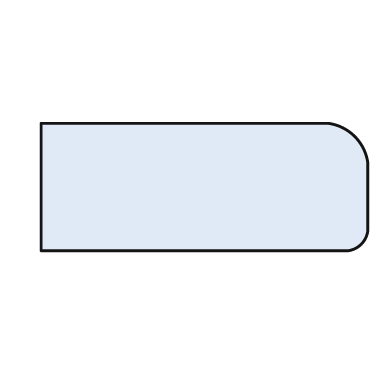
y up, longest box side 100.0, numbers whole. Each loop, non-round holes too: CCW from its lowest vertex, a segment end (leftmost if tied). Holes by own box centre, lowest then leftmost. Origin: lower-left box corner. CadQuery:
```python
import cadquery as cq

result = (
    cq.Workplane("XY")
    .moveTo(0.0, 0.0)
    .lineTo(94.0, 0.0)
    .threePointArc((98.0, 2.0), (100.0, 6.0))
    .lineTo(100.0, 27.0)
    .threePointArc((96.0, 35.0), (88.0, 39.0))
    .lineTo(0.0, 39.0)
    .close()
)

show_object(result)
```